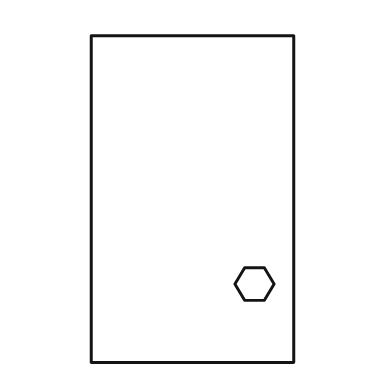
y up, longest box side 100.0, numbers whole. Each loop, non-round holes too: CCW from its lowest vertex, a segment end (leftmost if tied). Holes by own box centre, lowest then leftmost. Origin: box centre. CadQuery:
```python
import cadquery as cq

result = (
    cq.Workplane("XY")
    .moveTo(-31.0, -50.0)
    .lineTo(31.0, -50.0)
    .lineTo(31.0, 50.0)
    .lineTo(-31.0, 50.0)
    .close()
    .moveTo(16.0, -31.0)
    .lineTo(22.0, -31.0)
    .lineTo(25.0, -26.0)
    .lineTo(22.0, -21.0)
    .lineTo(16.0, -21.0)
    .lineTo(13.0, -26.0)
    .close()
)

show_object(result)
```